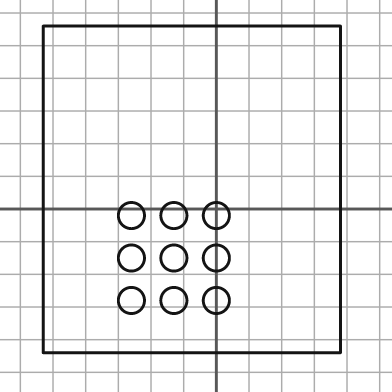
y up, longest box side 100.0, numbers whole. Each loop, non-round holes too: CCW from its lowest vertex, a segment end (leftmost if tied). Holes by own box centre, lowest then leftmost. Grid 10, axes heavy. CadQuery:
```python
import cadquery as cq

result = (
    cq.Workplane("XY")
    .moveTo(-53.0, -44.0)
    .lineTo(38.0, -44.0)
    .lineTo(38.0, 56.0)
    .lineTo(-53.0, 56.0)
    .close()
    .moveTo(-26.0, -28.0)
    .circle(4.0)
    .moveTo(-13.0, -28.0)
    .circle(4.0)
    .moveTo(0.0, -28.0)
    .circle(4.0)
    .moveTo(-26.0, -15.0)
    .circle(4.0)
    .moveTo(-13.0, -15.0)
    .circle(4.0)
    .moveTo(0.0, -15.0)
    .circle(4.0)
    .moveTo(-26.0, -2.0)
    .circle(4.0)
    .moveTo(-13.0, -2.0)
    .circle(4.0)
    .moveTo(0.0, -2.0)
    .circle(4.0)
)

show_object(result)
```